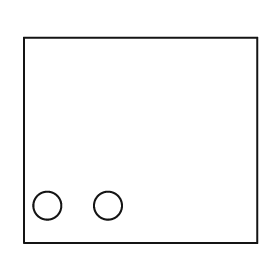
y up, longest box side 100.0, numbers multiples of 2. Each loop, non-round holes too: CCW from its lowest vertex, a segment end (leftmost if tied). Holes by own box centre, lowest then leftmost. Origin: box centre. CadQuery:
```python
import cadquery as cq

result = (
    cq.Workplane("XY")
    .moveTo(-50.0, -44.0)
    .lineTo(50.0, -44.0)
    .lineTo(50.0, 44.0)
    .lineTo(-50.0, 44.0)
    .close()
    .moveTo(-40.0, -28.0)
    .circle(6.0)
    .moveTo(-14.0, -28.0)
    .circle(6.0)
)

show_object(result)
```